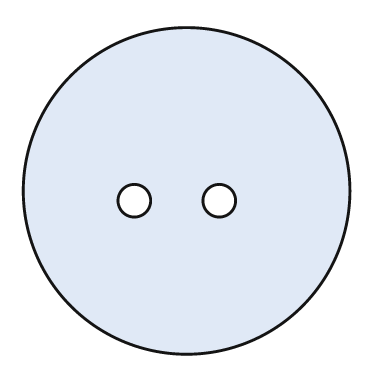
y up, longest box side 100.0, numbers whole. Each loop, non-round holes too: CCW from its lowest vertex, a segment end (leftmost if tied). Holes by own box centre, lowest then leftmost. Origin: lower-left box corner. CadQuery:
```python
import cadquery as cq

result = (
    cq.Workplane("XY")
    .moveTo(50.0, 50.0)
    .circle(50.0)
    .moveTo(34.0, 47.0)
    .circle(5.0)
    .moveTo(60.0, 47.0)
    .circle(5.0)
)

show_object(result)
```